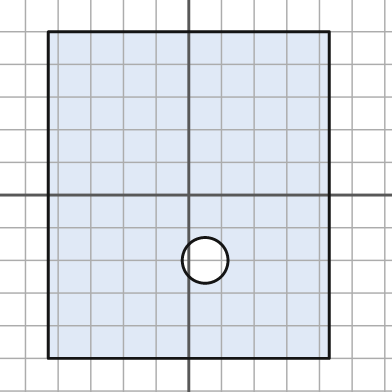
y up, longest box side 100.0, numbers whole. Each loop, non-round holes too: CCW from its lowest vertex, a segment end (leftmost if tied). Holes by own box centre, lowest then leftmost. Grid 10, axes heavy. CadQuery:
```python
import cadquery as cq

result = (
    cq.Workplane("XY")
    .moveTo(-43.0, -50.0)
    .lineTo(43.0, -50.0)
    .lineTo(43.0, 50.0)
    .lineTo(-43.0, 50.0)
    .close()
    .moveTo(5.0, -20.0)
    .circle(7.0)
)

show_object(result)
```